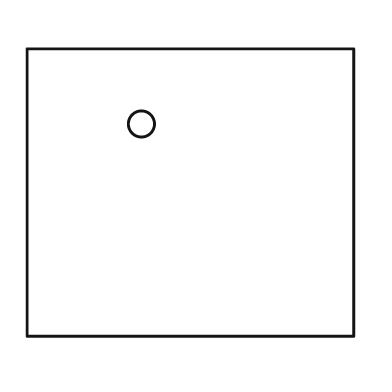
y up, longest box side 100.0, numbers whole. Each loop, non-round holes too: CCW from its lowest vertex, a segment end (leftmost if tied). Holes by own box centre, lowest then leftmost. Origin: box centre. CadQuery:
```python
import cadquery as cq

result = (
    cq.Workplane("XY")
    .moveTo(-50.0, -44.0)
    .lineTo(50.0, -44.0)
    .lineTo(50.0, 44.0)
    .lineTo(-50.0, 44.0)
    .close()
    .moveTo(-15.0, 21.0)
    .circle(4.0)
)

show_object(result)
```